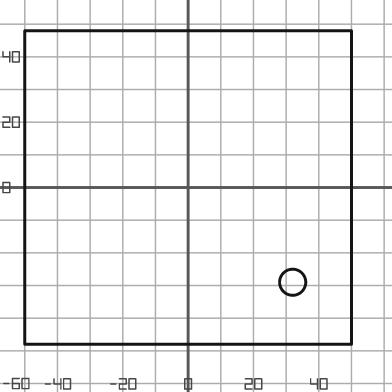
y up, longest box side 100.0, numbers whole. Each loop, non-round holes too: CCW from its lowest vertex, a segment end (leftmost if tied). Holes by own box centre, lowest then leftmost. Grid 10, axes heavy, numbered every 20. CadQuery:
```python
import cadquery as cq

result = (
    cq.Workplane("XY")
    .moveTo(-50.0, -48.0)
    .lineTo(50.0, -48.0)
    .lineTo(50.0, 48.0)
    .lineTo(-50.0, 48.0)
    .close()
    .moveTo(32.0, -29.0)
    .circle(4.0)
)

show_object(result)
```